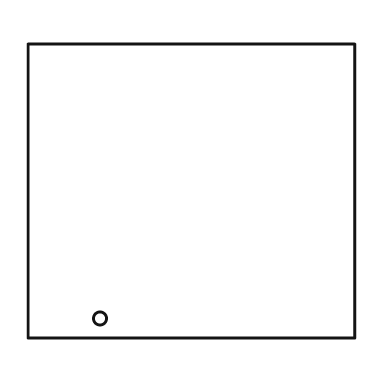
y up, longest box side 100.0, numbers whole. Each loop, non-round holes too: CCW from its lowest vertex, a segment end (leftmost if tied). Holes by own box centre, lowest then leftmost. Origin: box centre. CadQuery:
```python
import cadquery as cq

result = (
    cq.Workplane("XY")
    .moveTo(-50.0, -45.0)
    .lineTo(50.0, -45.0)
    .lineTo(50.0, 45.0)
    .lineTo(-50.0, 45.0)
    .close()
    .moveTo(-28.0, -39.0)
    .circle(2.0)
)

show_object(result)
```